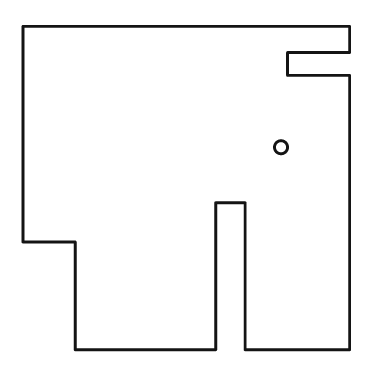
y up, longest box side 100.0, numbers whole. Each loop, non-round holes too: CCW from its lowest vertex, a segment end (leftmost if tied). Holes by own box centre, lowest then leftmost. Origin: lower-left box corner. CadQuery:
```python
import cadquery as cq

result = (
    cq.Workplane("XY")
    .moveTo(16.0, 0.0)
    .lineTo(59.0, 0.0)
    .lineTo(59.0, 45.0)
    .lineTo(68.0, 45.0)
    .lineTo(68.0, 0.0)
    .lineTo(100.0, 0.0)
    .lineTo(100.0, 84.0)
    .lineTo(81.0, 84.0)
    .lineTo(81.0, 91.0)
    .lineTo(100.0, 91.0)
    .lineTo(100.0, 99.0)
    .lineTo(0.0, 99.0)
    .lineTo(0.0, 33.0)
    .lineTo(16.0, 33.0)
    .close()
    .moveTo(79.0, 62.0)
    .circle(2.0)
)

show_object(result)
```